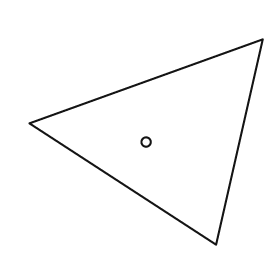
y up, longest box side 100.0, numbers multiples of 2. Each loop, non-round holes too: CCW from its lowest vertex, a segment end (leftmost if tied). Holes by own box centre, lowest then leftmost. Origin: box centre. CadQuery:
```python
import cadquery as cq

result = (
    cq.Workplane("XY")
    .moveTo(30.0, -44.0)
    .lineTo(50.0, 44.0)
    .lineTo(-50.0, 8.0)
    .close()
    .moveTo(0.0, 0.0)
    .circle(2.0)
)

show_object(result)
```